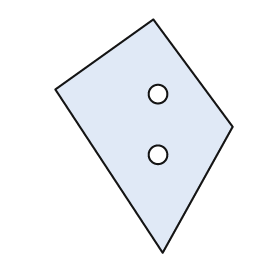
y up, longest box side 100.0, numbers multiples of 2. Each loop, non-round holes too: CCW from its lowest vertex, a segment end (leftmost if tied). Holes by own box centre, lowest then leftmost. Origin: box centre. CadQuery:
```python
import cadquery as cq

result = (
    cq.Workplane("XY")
    .moveTo(8.0, -50.0)
    .lineTo(38.0, 4.0)
    .lineTo(4.0, 50.0)
    .lineTo(-38.0, 20.0)
    .close()
    .moveTo(6.0, -8.0)
    .circle(4.0)
    .moveTo(6.0, 18.0)
    .circle(4.0)
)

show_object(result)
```